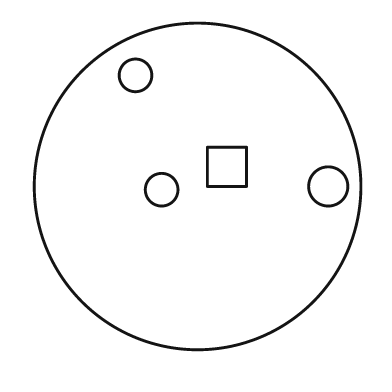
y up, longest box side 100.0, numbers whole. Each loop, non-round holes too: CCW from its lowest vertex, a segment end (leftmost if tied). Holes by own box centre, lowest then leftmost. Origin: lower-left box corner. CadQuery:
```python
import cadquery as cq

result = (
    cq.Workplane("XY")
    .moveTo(50.0, 50.0)
    .circle(50.0)
    .moveTo(39.0, 49.0)
    .circle(5.0)
    .moveTo(90.0, 50.0)
    .circle(6.0)
    .moveTo(53.0, 50.0)
    .lineTo(65.0, 50.0)
    .lineTo(65.0, 62.0)
    .lineTo(53.0, 62.0)
    .close()
    .moveTo(31.0, 84.0)
    .circle(5.0)
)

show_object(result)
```